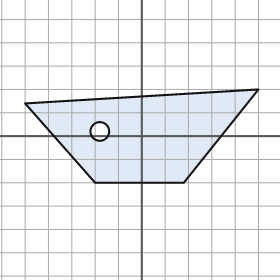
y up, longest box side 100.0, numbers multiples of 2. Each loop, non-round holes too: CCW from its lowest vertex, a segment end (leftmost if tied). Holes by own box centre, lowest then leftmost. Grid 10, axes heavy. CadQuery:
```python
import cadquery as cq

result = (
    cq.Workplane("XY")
    .moveTo(-20.0, -20.0)
    .lineTo(18.0, -20.0)
    .lineTo(50.0, 20.0)
    .lineTo(-50.0, 14.0)
    .close()
    .moveTo(-18.0, 2.0)
    .circle(4.0)
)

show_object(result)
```